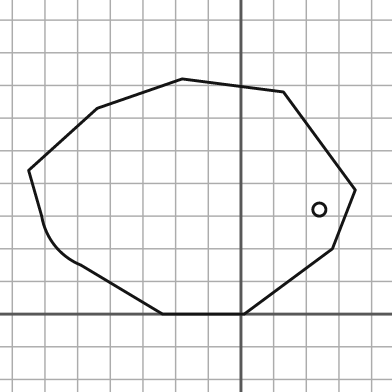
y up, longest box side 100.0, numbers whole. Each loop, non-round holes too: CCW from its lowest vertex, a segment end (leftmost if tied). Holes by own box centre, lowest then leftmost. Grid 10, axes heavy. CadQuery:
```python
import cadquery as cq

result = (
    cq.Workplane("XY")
    .moveTo(-24.0, 0.0)
    .lineTo(1.0, 0.0)
    .lineTo(28.0, 20.0)
    .lineTo(35.0, 38.0)
    .lineTo(13.0, 68.0)
    .lineTo(-18.0, 72.0)
    .lineTo(-44.0, 63.0)
    .lineTo(-65.0, 44.0)
    .lineTo(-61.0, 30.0)
    .threePointArc((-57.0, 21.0), (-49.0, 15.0))
    .close()
    .moveTo(24.0, 32.0)
    .circle(2.0)
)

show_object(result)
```